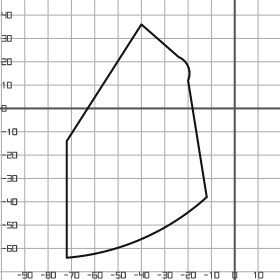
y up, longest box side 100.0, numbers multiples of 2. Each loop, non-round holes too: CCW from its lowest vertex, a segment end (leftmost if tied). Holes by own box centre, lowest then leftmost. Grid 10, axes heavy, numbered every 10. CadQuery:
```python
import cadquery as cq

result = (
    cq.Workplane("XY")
    .moveTo(-72.0, -64.0)
    .threePointArc((-40.0, -56.0), (-12.0, -38.0))
    .lineTo(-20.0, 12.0)
    .threePointArc((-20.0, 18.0), (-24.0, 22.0))
    .lineTo(-40.0, 36.0)
    .lineTo(-72.0, -14.0)
    .close()
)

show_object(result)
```